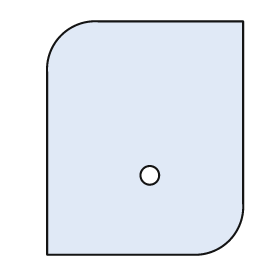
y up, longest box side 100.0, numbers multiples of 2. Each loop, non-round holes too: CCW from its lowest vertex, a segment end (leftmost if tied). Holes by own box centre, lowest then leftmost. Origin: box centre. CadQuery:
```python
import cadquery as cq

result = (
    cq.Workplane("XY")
    .moveTo(-42.0, -50.0)
    .lineTo(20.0, -50.0)
    .threePointArc((36.0, -44.0), (42.0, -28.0))
    .lineTo(42.0, 50.0)
    .lineTo(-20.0, 50.0)
    .threePointArc((-36.0, 44.0), (-42.0, 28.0))
    .close()
    .moveTo(2.0, -16.0)
    .circle(4.0)
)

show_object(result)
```